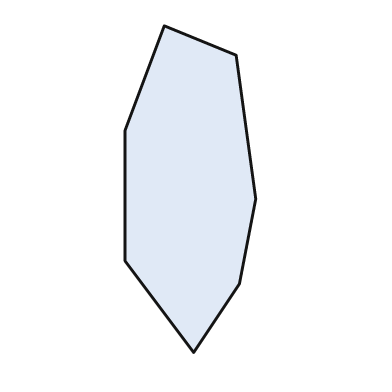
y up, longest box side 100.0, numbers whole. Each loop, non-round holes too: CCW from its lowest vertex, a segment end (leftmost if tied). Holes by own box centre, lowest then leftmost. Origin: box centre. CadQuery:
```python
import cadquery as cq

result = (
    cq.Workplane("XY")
    .moveTo(1.0, -50.0)
    .lineTo(15.0, -29.0)
    .lineTo(20.0, -3.0)
    .lineTo(14.0, 41.0)
    .lineTo(-8.0, 50.0)
    .lineTo(-20.0, 18.0)
    .lineTo(-20.0, -22.0)
    .close()
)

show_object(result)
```